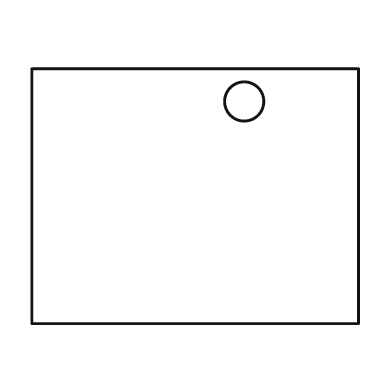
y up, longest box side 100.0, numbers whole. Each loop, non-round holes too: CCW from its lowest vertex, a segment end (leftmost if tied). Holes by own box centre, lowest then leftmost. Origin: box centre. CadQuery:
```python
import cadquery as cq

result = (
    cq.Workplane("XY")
    .moveTo(-50.0, -39.0)
    .lineTo(50.0, -39.0)
    .lineTo(50.0, 39.0)
    .lineTo(-50.0, 39.0)
    .close()
    .moveTo(15.0, 29.0)
    .circle(6.0)
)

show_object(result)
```